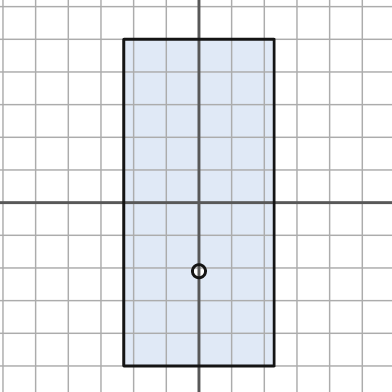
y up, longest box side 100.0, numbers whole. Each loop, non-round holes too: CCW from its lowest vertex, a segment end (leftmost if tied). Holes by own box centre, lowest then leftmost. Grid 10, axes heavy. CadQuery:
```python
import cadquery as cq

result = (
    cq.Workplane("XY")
    .moveTo(-23.0, -50.0)
    .lineTo(23.0, -50.0)
    .lineTo(23.0, 50.0)
    .lineTo(-23.0, 50.0)
    .close()
    .moveTo(0.0, -21.0)
    .circle(2.0)
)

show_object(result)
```